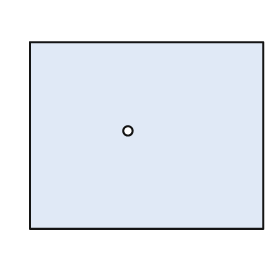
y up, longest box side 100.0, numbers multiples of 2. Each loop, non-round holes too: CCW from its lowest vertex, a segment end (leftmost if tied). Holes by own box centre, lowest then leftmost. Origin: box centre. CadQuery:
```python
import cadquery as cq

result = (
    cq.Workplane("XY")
    .moveTo(-50.0, -40.0)
    .lineTo(50.0, -40.0)
    .lineTo(50.0, 40.0)
    .lineTo(-50.0, 40.0)
    .close()
    .moveTo(-8.0, 2.0)
    .circle(2.0)
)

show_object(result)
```